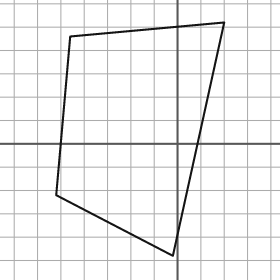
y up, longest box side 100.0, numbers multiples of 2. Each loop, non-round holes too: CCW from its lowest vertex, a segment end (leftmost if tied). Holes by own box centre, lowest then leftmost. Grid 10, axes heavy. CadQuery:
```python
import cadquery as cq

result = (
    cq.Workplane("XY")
    .moveTo(-2.0, -48.0)
    .lineTo(20.0, 52.0)
    .lineTo(-46.0, 46.0)
    .lineTo(-52.0, -22.0)
    .close()
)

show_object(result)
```